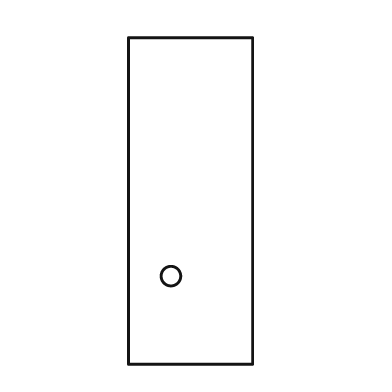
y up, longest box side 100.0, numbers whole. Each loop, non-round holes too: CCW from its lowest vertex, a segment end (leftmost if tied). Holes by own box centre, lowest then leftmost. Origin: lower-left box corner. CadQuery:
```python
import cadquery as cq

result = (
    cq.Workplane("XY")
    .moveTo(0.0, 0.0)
    .lineTo(38.0, 0.0)
    .lineTo(38.0, 100.0)
    .lineTo(0.0, 100.0)
    .close()
    .moveTo(13.0, 27.0)
    .circle(3.0)
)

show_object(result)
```